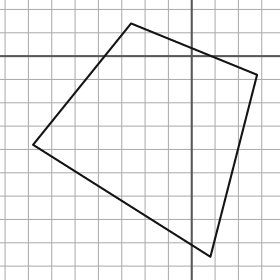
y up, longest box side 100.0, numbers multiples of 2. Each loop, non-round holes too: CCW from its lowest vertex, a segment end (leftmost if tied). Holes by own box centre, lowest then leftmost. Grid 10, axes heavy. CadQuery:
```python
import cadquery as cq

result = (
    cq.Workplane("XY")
    .moveTo(8.0, -86.0)
    .lineTo(28.0, -8.0)
    .lineTo(-26.0, 14.0)
    .lineTo(-68.0, -38.0)
    .close()
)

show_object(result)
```